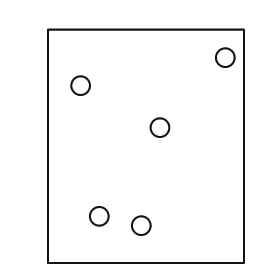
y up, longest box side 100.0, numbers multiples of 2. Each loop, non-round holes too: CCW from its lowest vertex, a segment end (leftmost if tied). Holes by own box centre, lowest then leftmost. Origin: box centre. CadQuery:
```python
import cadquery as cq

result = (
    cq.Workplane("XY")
    .moveTo(-42.0, -50.0)
    .lineTo(42.0, -50.0)
    .lineTo(42.0, 50.0)
    .lineTo(-42.0, 50.0)
    .close()
    .moveTo(-2.0, -34.0)
    .circle(4.0)
    .moveTo(-20.0, -30.0)
    .circle(4.0)
    .moveTo(6.0, 8.0)
    .circle(4.0)
    .moveTo(-28.0, 26.0)
    .circle(4.0)
    .moveTo(34.0, 38.0)
    .circle(4.0)
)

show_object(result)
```